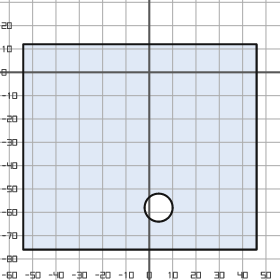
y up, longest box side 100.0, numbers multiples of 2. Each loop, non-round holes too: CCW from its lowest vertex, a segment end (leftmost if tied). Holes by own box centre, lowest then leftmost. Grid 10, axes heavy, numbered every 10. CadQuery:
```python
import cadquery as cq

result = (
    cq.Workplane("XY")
    .moveTo(-54.0, -76.0)
    .lineTo(46.0, -76.0)
    .lineTo(46.0, 12.0)
    .lineTo(-54.0, 12.0)
    .close()
    .moveTo(4.0, -58.0)
    .circle(6.0)
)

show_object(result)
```